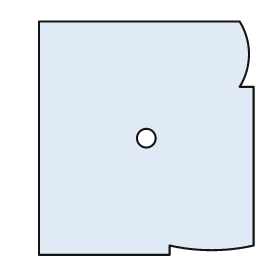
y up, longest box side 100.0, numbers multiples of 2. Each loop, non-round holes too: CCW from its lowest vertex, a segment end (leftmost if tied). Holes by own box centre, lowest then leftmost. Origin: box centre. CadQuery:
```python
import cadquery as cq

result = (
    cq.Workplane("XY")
    .moveTo(-46.0, -50.0)
    .lineTo(10.0, -50.0)
    .lineTo(10.0, -46.0)
    .threePointArc((28.0, -48.0), (46.0, -46.0))
    .lineTo(46.0, 22.0)
    .lineTo(40.0, 22.0)
    .threePointArc((44.0, 36.0), (40.0, 50.0))
    .lineTo(-46.0, 50.0)
    .close()
    .moveTo(0.0, 0.0)
    .circle(4.0)
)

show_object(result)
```